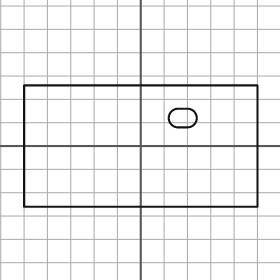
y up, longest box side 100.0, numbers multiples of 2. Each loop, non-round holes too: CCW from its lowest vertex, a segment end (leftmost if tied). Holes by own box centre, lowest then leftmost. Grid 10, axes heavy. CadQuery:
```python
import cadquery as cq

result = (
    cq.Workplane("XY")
    .moveTo(-50.0, -26.0)
    .lineTo(50.0, -26.0)
    .lineTo(50.0, 26.0)
    .lineTo(-50.0, 26.0)
    .close()
    .moveTo(16.0, 8.0)
    .lineTo(20.0, 8.0)
    .threePointArc((24.0, 12.0), (20.0, 16.0))
    .lineTo(16.0, 16.0)
    .threePointArc((12.0, 12.0), (16.0, 8.0))
    .close()
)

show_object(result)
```